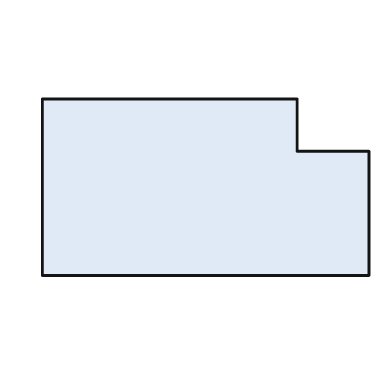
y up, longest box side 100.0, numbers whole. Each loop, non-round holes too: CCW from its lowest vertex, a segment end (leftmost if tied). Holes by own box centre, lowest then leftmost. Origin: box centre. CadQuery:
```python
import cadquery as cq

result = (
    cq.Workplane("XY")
    .moveTo(-50.0, -27.0)
    .lineTo(50.0, -27.0)
    .lineTo(50.0, 11.0)
    .lineTo(28.0, 11.0)
    .lineTo(28.0, 27.0)
    .lineTo(-50.0, 27.0)
    .close()
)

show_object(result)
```